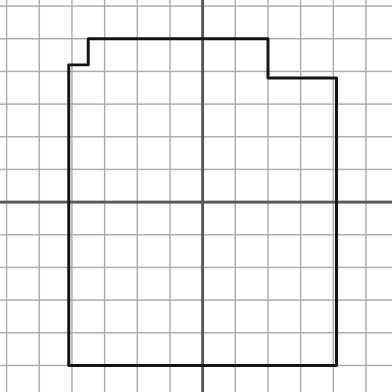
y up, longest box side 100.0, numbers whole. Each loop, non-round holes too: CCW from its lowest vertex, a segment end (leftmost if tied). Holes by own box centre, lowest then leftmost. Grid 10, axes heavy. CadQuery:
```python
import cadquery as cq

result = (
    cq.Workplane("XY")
    .moveTo(-41.0, -50.0)
    .lineTo(41.0, -50.0)
    .lineTo(41.0, 38.0)
    .lineTo(20.0, 38.0)
    .lineTo(20.0, 50.0)
    .lineTo(-35.0, 50.0)
    .lineTo(-35.0, 42.0)
    .lineTo(-41.0, 42.0)
    .close()
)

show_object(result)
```